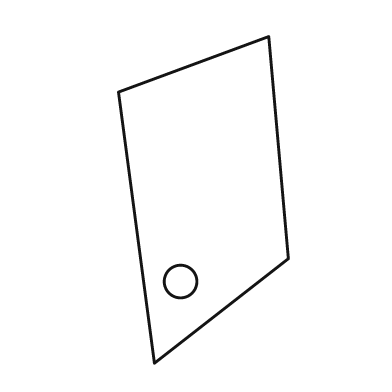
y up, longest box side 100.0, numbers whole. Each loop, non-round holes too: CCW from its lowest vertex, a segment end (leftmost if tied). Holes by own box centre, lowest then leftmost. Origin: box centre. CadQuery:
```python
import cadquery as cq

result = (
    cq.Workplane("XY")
    .moveTo(-15.0, -50.0)
    .lineTo(26.0, -18.0)
    .lineTo(20.0, 50.0)
    .lineTo(-26.0, 33.0)
    .close()
    .moveTo(-7.0, -25.0)
    .circle(5.0)
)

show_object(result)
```